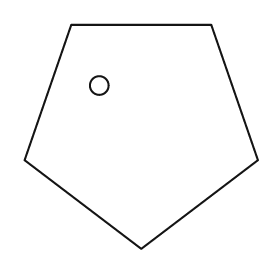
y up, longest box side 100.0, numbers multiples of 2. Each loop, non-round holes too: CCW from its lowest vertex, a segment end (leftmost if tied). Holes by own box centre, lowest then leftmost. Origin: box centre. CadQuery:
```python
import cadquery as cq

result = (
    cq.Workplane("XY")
    .moveTo(0.0, -48.0)
    .lineTo(50.0, -10.0)
    .lineTo(30.0, 48.0)
    .lineTo(-30.0, 48.0)
    .lineTo(-50.0, -10.0)
    .close()
    .moveTo(-18.0, 22.0)
    .circle(4.0)
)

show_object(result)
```